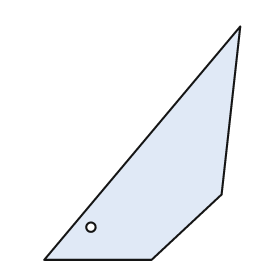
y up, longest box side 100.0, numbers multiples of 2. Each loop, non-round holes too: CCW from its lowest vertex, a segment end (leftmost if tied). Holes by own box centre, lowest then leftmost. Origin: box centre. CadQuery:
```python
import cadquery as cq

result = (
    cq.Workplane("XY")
    .moveTo(-42.0, -50.0)
    .lineTo(4.0, -50.0)
    .lineTo(34.0, -22.0)
    .lineTo(42.0, 50.0)
    .close()
    .moveTo(-22.0, -36.0)
    .circle(2.0)
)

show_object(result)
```